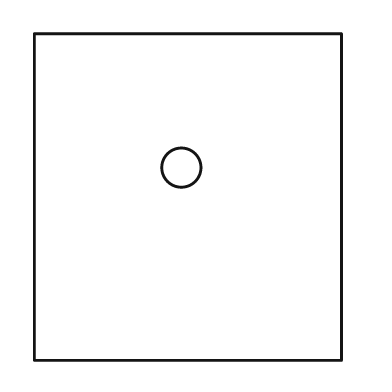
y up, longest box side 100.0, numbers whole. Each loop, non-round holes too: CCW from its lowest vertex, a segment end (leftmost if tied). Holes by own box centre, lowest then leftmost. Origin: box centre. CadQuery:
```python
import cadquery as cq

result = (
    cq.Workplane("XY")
    .moveTo(-47.0, -50.0)
    .lineTo(47.0, -50.0)
    .lineTo(47.0, 50.0)
    .lineTo(-47.0, 50.0)
    .close()
    .moveTo(-2.0, 9.0)
    .circle(6.0)
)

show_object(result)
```